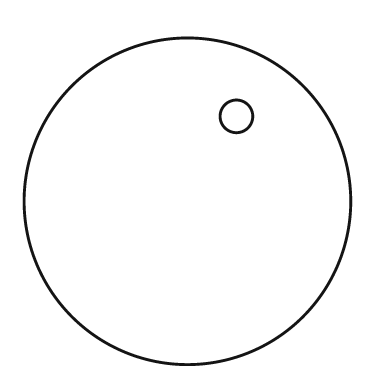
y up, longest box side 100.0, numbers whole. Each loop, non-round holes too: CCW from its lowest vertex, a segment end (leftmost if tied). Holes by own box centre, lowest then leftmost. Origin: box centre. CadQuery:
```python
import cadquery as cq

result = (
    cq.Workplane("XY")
    .moveTo(0.0, 0.0)
    .circle(50.0)
    .moveTo(15.0, 26.0)
    .circle(5.0)
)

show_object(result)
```